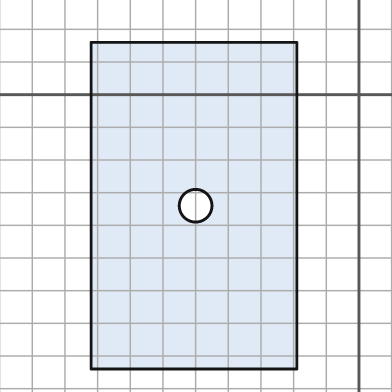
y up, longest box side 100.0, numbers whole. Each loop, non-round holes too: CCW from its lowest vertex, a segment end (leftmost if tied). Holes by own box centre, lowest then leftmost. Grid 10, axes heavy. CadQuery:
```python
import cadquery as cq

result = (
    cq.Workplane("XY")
    .moveTo(-82.0, -84.0)
    .lineTo(-19.0, -84.0)
    .lineTo(-19.0, 16.0)
    .lineTo(-82.0, 16.0)
    .close()
    .moveTo(-50.0, -34.0)
    .circle(5.0)
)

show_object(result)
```